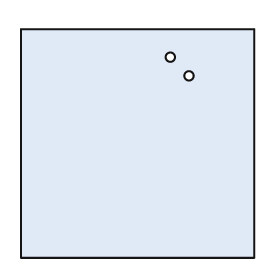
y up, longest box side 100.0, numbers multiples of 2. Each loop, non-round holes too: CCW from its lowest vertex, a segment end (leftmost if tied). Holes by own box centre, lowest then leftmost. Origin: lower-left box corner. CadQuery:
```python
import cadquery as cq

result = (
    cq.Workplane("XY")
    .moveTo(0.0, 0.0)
    .lineTo(100.0, 0.0)
    .lineTo(100.0, 98.0)
    .lineTo(0.0, 98.0)
    .close()
    .moveTo(72.0, 78.0)
    .circle(2.0)
    .moveTo(64.0, 86.0)
    .circle(2.0)
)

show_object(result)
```